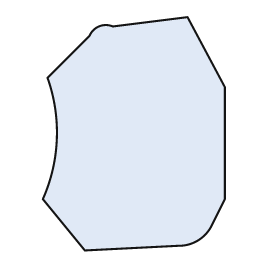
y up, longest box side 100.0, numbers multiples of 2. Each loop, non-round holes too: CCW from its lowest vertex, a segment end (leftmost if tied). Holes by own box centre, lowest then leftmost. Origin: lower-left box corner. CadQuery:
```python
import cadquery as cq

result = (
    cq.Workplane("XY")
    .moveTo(18.0, 0.0)
    .lineTo(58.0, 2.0)
    .threePointArc((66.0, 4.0), (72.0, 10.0))
    .lineTo(78.0, 22.0)
    .lineTo(78.0, 70.0)
    .lineTo(62.0, 100.0)
    .lineTo(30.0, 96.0)
    .threePointArc((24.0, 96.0), (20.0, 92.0))
    .lineTo(2.0, 74.0)
    .threePointArc((6.0, 48.0), (0.0, 22.0))
    .close()
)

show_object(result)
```